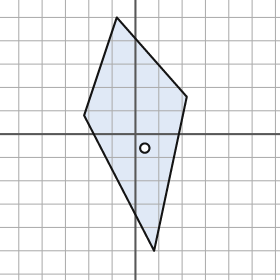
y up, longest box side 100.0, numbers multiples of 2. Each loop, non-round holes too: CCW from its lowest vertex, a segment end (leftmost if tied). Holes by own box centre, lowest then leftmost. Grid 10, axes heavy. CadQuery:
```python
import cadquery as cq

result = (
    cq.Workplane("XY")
    .moveTo(8.0, -50.0)
    .lineTo(22.0, 16.0)
    .lineTo(-8.0, 50.0)
    .lineTo(-22.0, 8.0)
    .close()
    .moveTo(4.0, -6.0)
    .circle(2.0)
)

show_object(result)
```